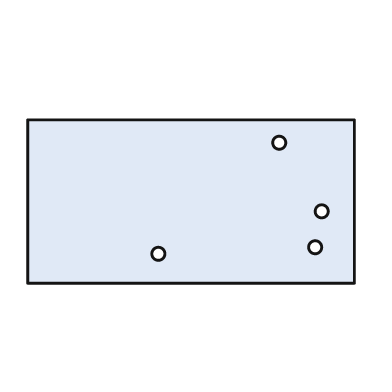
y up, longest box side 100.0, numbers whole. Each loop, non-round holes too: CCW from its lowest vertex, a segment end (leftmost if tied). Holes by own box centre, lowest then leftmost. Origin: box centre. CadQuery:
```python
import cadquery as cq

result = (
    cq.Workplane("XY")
    .moveTo(-50.0, -25.0)
    .lineTo(50.0, -25.0)
    .lineTo(50.0, 25.0)
    .lineTo(-50.0, 25.0)
    .close()
    .moveTo(-10.0, -16.0)
    .circle(2.0)
    .moveTo(38.0, -14.0)
    .circle(2.0)
    .moveTo(40.0, -3.0)
    .circle(2.0)
    .moveTo(27.0, 18.0)
    .circle(2.0)
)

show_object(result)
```